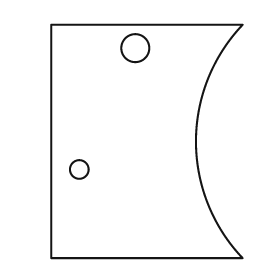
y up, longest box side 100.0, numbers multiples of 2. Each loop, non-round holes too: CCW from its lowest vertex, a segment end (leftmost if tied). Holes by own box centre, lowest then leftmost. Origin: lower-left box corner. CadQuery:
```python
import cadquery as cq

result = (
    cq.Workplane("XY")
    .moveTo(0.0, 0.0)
    .lineTo(82.0, 0.0)
    .threePointArc((62.0, 50.0), (82.0, 100.0))
    .lineTo(0.0, 100.0)
    .close()
    .moveTo(12.0, 38.0)
    .circle(4.0)
    .moveTo(36.0, 90.0)
    .circle(6.0)
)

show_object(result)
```